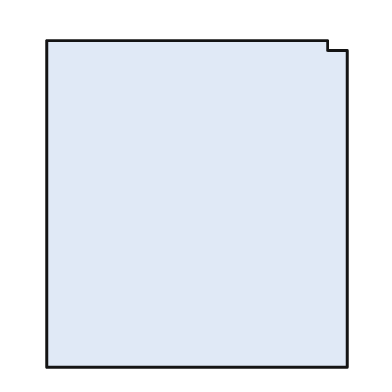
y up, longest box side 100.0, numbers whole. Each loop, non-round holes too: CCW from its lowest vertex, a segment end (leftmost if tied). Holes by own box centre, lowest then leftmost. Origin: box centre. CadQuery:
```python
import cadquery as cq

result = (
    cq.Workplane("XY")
    .moveTo(-46.0, -50.0)
    .lineTo(46.0, -50.0)
    .lineTo(46.0, 47.0)
    .lineTo(40.0, 47.0)
    .lineTo(40.0, 50.0)
    .lineTo(-46.0, 50.0)
    .close()
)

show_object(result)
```